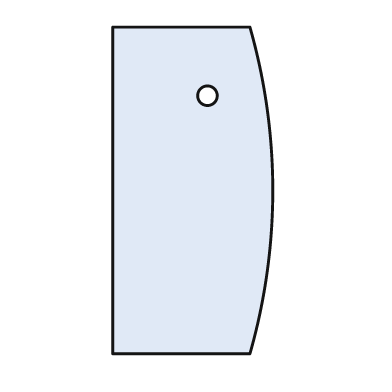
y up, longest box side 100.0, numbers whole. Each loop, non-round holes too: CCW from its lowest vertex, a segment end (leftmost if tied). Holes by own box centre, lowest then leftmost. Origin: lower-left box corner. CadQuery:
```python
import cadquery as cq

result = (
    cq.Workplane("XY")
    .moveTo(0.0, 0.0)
    .lineTo(42.0, 0.0)
    .threePointArc((49.0, 50.0), (42.0, 100.0))
    .lineTo(0.0, 100.0)
    .close()
    .moveTo(29.0, 79.0)
    .circle(3.0)
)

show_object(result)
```